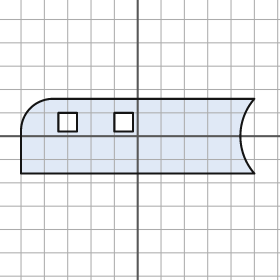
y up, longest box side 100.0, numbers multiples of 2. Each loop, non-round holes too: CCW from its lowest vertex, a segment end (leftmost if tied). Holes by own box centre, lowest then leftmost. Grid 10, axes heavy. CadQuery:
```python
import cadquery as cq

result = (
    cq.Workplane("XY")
    .moveTo(-50.0, -16.0)
    .lineTo(50.0, -16.0)
    .threePointArc((44.0, 0.0), (50.0, 16.0))
    .lineTo(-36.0, 16.0)
    .threePointArc((-46.0, 12.0), (-50.0, 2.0))
    .close()
    .moveTo(-34.0, 2.0)
    .lineTo(-26.0, 2.0)
    .lineTo(-26.0, 10.0)
    .lineTo(-34.0, 10.0)
    .close()
    .moveTo(-10.0, 2.0)
    .lineTo(-2.0, 2.0)
    .lineTo(-2.0, 10.0)
    .lineTo(-10.0, 10.0)
    .close()
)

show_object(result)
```